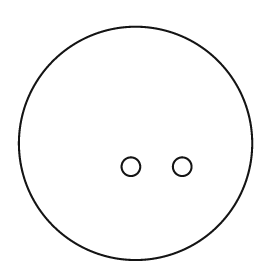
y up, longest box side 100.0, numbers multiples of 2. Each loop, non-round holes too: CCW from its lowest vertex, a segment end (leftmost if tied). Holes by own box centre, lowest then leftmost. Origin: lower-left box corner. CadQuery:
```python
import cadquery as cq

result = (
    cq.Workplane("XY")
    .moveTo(50.0, 50.0)
    .circle(50.0)
    .moveTo(48.0, 40.0)
    .circle(4.0)
    .moveTo(70.0, 40.0)
    .circle(4.0)
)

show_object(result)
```